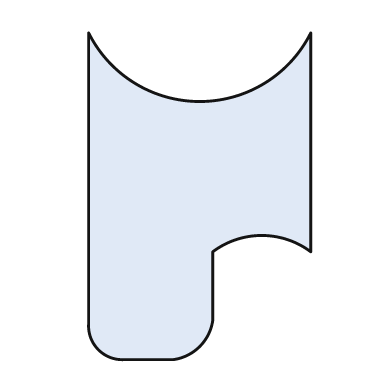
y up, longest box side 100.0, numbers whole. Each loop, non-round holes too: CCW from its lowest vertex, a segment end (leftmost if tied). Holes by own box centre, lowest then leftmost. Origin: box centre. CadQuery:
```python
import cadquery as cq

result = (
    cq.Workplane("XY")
    .moveTo(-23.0, -50.0)
    .lineTo(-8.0, -50.0)
    .threePointArc((0.0, -46.0), (4.0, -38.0))
    .lineTo(4.0, -17.0)
    .threePointArc((19.0, -12.0), (34.0, -17.0))
    .lineTo(34.0, 50.0)
    .threePointArc((0.0, 29.0), (-34.0, 50.0))
    .lineTo(-34.0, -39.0)
    .threePointArc((-31.0, -47.0), (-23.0, -50.0))
    .close()
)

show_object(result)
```